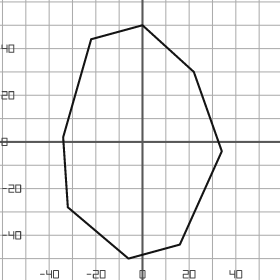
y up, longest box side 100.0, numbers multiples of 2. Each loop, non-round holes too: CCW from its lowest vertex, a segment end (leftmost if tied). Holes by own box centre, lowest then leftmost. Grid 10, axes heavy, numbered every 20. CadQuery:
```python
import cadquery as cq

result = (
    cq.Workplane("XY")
    .moveTo(-6.0, -50.0)
    .lineTo(16.0, -44.0)
    .lineTo(34.0, -4.0)
    .lineTo(22.0, 30.0)
    .lineTo(0.0, 50.0)
    .lineTo(-22.0, 44.0)
    .lineTo(-34.0, 2.0)
    .lineTo(-32.0, -28.0)
    .close()
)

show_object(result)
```